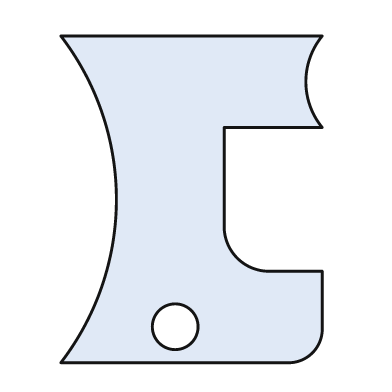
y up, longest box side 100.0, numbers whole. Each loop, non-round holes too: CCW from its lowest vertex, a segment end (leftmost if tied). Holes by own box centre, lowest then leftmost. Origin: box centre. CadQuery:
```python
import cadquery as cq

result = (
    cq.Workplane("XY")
    .moveTo(-40.0, -50.0)
    .lineTo(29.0, -50.0)
    .threePointArc((37.0, -47.0), (40.0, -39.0))
    .lineTo(40.0, -22.0)
    .lineTo(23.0, -22.0)
    .threePointArc((14.0, -18.0), (10.0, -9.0))
    .lineTo(10.0, 22.0)
    .lineTo(40.0, 22.0)
    .threePointArc((35.0, 36.0), (40.0, 50.0))
    .lineTo(-40.0, 50.0)
    .threePointArc((-23.0, 0.0), (-40.0, -50.0))
    .close()
    .moveTo(-5.0, -39.0)
    .circle(7.0)
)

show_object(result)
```